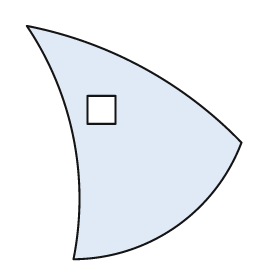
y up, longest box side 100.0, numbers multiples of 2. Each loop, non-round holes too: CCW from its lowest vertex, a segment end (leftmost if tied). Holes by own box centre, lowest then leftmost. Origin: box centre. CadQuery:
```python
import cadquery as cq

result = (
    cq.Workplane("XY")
    .moveTo(-26.0, -50.0)
    .threePointArc((18.0, -36.0), (46.0, 0.0))
    .threePointArc((4.0, 32.0), (-46.0, 50.0))
    .threePointArc((-26.0, 2.0), (-26.0, -50.0))
    .close()
    .moveTo(-20.0, 8.0)
    .lineTo(-8.0, 8.0)
    .lineTo(-8.0, 20.0)
    .lineTo(-20.0, 20.0)
    .close()
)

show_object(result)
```